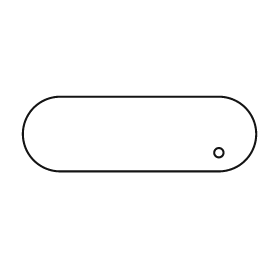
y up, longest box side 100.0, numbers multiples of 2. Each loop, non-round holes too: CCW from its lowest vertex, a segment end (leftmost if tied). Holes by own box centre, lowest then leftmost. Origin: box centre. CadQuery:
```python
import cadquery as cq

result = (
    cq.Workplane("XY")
    .moveTo(-34.0, -16.0)
    .lineTo(34.0, -16.0)
    .threePointArc((50.0, 0.0), (34.0, 16.0))
    .lineTo(-34.0, 16.0)
    .threePointArc((-50.0, 0.0), (-34.0, -16.0))
    .close()
    .moveTo(34.0, -8.0)
    .circle(2.0)
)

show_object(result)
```